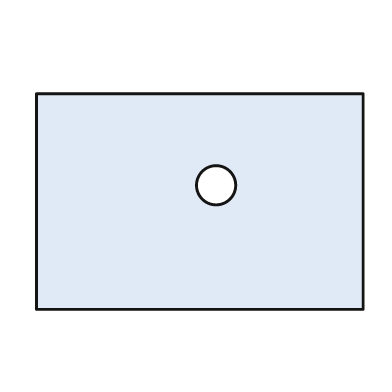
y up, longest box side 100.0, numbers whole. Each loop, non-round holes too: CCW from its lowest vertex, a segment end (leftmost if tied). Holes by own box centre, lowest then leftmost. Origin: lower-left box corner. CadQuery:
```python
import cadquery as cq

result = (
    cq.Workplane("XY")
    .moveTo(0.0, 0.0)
    .lineTo(100.0, 0.0)
    .lineTo(100.0, 66.0)
    .lineTo(0.0, 66.0)
    .close()
    .moveTo(55.0, 38.0)
    .circle(6.0)
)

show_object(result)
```